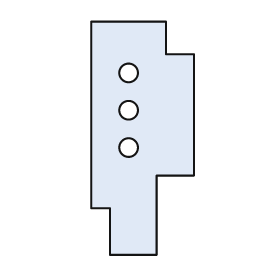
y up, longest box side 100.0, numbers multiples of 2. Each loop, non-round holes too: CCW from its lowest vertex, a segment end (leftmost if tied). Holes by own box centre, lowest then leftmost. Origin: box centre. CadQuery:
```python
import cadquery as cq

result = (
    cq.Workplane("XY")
    .moveTo(-14.0, -50.0)
    .lineTo(6.0, -50.0)
    .lineTo(6.0, -16.0)
    .lineTo(22.0, -16.0)
    .lineTo(22.0, 36.0)
    .lineTo(10.0, 36.0)
    .lineTo(10.0, 50.0)
    .lineTo(-22.0, 50.0)
    .lineTo(-22.0, -30.0)
    .lineTo(-14.0, -30.0)
    .close()
    .moveTo(-6.0, -4.0)
    .circle(4.0)
    .moveTo(-6.0, 12.0)
    .circle(4.0)
    .moveTo(-6.0, 28.0)
    .circle(4.0)
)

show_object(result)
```